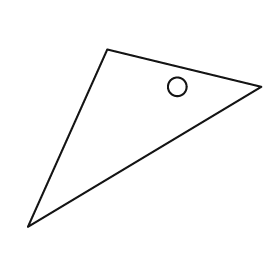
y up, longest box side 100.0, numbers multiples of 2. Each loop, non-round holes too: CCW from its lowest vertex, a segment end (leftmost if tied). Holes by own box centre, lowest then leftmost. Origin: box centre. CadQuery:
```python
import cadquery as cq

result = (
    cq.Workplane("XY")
    .moveTo(-50.0, -38.0)
    .lineTo(50.0, 22.0)
    .lineTo(-16.0, 38.0)
    .close()
    .moveTo(14.0, 22.0)
    .circle(4.0)
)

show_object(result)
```